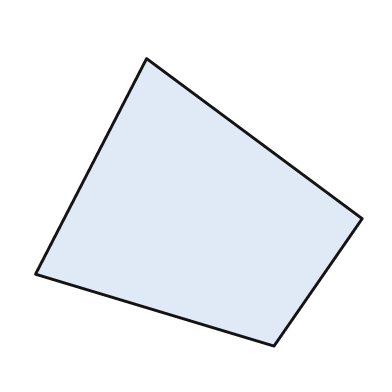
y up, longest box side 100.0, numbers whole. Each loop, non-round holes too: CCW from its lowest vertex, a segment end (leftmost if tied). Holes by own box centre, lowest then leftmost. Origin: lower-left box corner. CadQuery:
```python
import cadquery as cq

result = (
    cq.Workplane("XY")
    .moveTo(73.0, 0.0)
    .lineTo(100.0, 39.0)
    .lineTo(34.0, 88.0)
    .lineTo(0.0, 22.0)
    .close()
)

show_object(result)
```